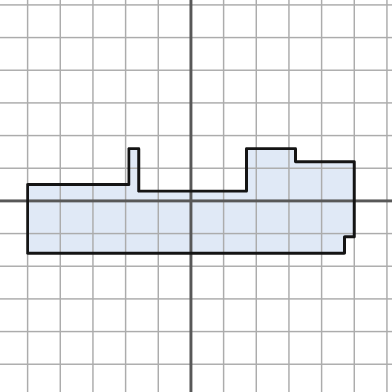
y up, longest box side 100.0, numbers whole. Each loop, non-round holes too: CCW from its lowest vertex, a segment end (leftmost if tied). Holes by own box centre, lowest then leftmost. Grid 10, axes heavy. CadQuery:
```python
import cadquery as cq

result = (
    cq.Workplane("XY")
    .moveTo(-50.0, -16.0)
    .lineTo(47.0, -16.0)
    .lineTo(47.0, -11.0)
    .lineTo(50.0, -11.0)
    .lineTo(50.0, 12.0)
    .lineTo(32.0, 12.0)
    .lineTo(32.0, 16.0)
    .lineTo(17.0, 16.0)
    .lineTo(17.0, 3.0)
    .lineTo(-16.0, 3.0)
    .lineTo(-16.0, 16.0)
    .lineTo(-19.0, 16.0)
    .lineTo(-19.0, 5.0)
    .lineTo(-50.0, 5.0)
    .close()
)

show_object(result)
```